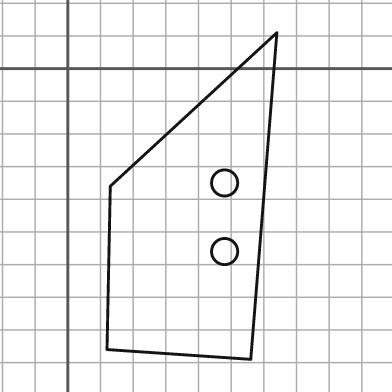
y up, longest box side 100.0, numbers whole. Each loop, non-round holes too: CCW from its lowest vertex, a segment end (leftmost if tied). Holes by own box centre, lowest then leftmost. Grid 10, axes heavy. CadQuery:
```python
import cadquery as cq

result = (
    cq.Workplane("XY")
    .moveTo(56.0, -89.0)
    .lineTo(64.0, 11.0)
    .lineTo(13.0, -36.0)
    .lineTo(12.0, -86.0)
    .close()
    .moveTo(48.0, -56.0)
    .circle(4.0)
    .moveTo(48.0, -35.0)
    .circle(4.0)
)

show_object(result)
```